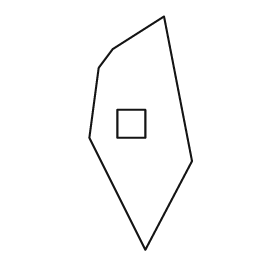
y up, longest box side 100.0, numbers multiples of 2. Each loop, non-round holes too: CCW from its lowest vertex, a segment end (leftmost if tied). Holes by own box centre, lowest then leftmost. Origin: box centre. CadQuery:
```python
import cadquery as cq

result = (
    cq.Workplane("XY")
    .moveTo(2.0, -50.0)
    .lineTo(22.0, -12.0)
    .lineTo(10.0, 50.0)
    .lineTo(-12.0, 36.0)
    .lineTo(-18.0, 28.0)
    .lineTo(-22.0, -2.0)
    .close()
    .moveTo(-10.0, -2.0)
    .lineTo(2.0, -2.0)
    .lineTo(2.0, 10.0)
    .lineTo(-10.0, 10.0)
    .close()
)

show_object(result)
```